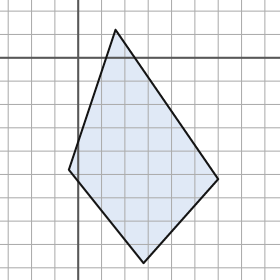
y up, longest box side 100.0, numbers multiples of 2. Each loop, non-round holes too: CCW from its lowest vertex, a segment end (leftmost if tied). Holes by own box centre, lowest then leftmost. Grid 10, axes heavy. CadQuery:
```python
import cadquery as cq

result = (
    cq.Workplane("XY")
    .moveTo(28.0, -88.0)
    .lineTo(60.0, -52.0)
    .lineTo(16.0, 12.0)
    .lineTo(-4.0, -48.0)
    .close()
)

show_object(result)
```